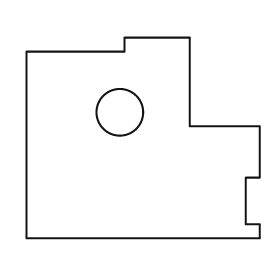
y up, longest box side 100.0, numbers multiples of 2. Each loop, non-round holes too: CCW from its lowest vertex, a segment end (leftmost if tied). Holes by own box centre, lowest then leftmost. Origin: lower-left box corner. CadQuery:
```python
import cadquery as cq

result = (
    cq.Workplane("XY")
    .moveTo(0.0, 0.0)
    .lineTo(100.0, 0.0)
    .lineTo(100.0, 6.0)
    .lineTo(94.0, 6.0)
    .lineTo(94.0, 26.0)
    .lineTo(100.0, 26.0)
    .lineTo(100.0, 48.0)
    .lineTo(70.0, 48.0)
    .lineTo(70.0, 86.0)
    .lineTo(42.0, 86.0)
    .lineTo(42.0, 80.0)
    .lineTo(0.0, 80.0)
    .close()
    .moveTo(40.0, 54.0)
    .circle(10.0)
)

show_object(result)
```